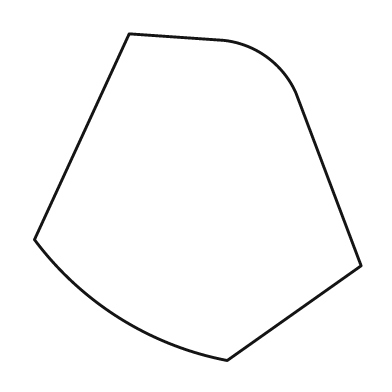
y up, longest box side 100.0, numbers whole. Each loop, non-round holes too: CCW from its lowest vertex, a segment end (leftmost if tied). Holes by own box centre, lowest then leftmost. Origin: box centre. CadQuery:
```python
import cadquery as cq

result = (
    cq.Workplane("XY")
    .moveTo(9.0, -50.0)
    .lineTo(50.0, -21.0)
    .lineTo(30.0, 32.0)
    .threePointArc((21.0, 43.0), (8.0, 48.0))
    .lineTo(-21.0, 50.0)
    .lineTo(-50.0, -13.0)
    .threePointArc((-24.0, -37.0), (9.0, -50.0))
    .close()
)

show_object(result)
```